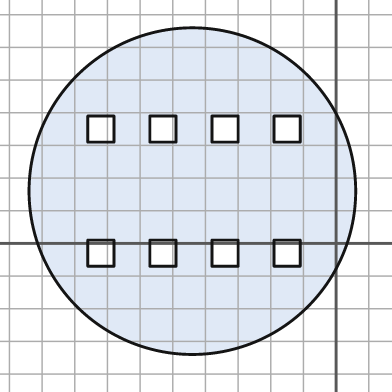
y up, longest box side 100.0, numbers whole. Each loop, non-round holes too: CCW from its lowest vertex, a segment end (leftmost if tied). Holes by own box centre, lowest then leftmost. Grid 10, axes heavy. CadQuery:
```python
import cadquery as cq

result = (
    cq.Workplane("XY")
    .moveTo(-44.0, 16.0)
    .circle(50.0)
    .moveTo(-76.0, -7.0)
    .lineTo(-68.0, -7.0)
    .lineTo(-68.0, 1.0)
    .lineTo(-76.0, 1.0)
    .close()
    .moveTo(-57.0, -7.0)
    .lineTo(-49.0, -7.0)
    .lineTo(-49.0, 1.0)
    .lineTo(-57.0, 1.0)
    .close()
    .moveTo(-38.0, -7.0)
    .lineTo(-30.0, -7.0)
    .lineTo(-30.0, 1.0)
    .lineTo(-38.0, 1.0)
    .close()
    .moveTo(-19.0, -7.0)
    .lineTo(-11.0, -7.0)
    .lineTo(-11.0, 1.0)
    .lineTo(-19.0, 1.0)
    .close()
    .moveTo(-76.0, 31.0)
    .lineTo(-68.0, 31.0)
    .lineTo(-68.0, 39.0)
    .lineTo(-76.0, 39.0)
    .close()
    .moveTo(-57.0, 31.0)
    .lineTo(-49.0, 31.0)
    .lineTo(-49.0, 39.0)
    .lineTo(-57.0, 39.0)
    .close()
    .moveTo(-38.0, 31.0)
    .lineTo(-30.0, 31.0)
    .lineTo(-30.0, 39.0)
    .lineTo(-38.0, 39.0)
    .close()
    .moveTo(-19.0, 31.0)
    .lineTo(-11.0, 31.0)
    .lineTo(-11.0, 39.0)
    .lineTo(-19.0, 39.0)
    .close()
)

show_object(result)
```